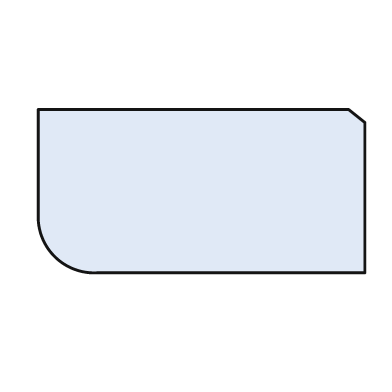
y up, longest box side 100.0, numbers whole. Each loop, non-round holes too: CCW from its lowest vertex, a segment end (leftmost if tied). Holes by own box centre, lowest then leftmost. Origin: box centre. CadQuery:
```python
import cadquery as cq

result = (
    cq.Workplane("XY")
    .moveTo(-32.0, -25.0)
    .lineTo(50.0, -25.0)
    .lineTo(50.0, 21.0)
    .lineTo(45.0, 25.0)
    .lineTo(-50.0, 25.0)
    .lineTo(-50.0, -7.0)
    .threePointArc((-45.0, -20.0), (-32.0, -25.0))
    .close()
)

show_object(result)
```